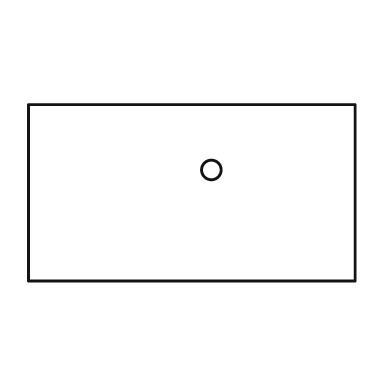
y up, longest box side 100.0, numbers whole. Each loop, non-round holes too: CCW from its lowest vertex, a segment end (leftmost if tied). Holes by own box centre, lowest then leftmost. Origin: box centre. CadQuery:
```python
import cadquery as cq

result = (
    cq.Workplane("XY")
    .moveTo(-50.0, -27.0)
    .lineTo(50.0, -27.0)
    .lineTo(50.0, 27.0)
    .lineTo(-50.0, 27.0)
    .close()
    .moveTo(6.0, 7.0)
    .circle(3.0)
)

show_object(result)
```